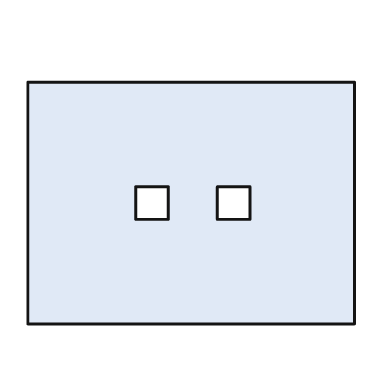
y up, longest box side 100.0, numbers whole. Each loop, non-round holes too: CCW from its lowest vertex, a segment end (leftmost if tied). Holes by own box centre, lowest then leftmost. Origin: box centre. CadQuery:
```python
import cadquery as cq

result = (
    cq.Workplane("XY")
    .moveTo(-50.0, -37.0)
    .lineTo(50.0, -37.0)
    .lineTo(50.0, 37.0)
    .lineTo(-50.0, 37.0)
    .close()
    .moveTo(-17.0, -5.0)
    .lineTo(-7.0, -5.0)
    .lineTo(-7.0, 5.0)
    .lineTo(-17.0, 5.0)
    .close()
    .moveTo(8.0, -5.0)
    .lineTo(18.0, -5.0)
    .lineTo(18.0, 5.0)
    .lineTo(8.0, 5.0)
    .close()
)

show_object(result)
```